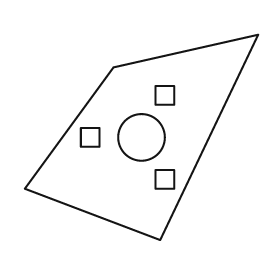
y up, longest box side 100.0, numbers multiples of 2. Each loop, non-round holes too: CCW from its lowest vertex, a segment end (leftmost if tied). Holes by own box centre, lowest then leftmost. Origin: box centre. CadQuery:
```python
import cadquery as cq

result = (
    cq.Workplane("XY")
    .moveTo(8.0, -44.0)
    .lineTo(50.0, 44.0)
    .lineTo(-12.0, 30.0)
    .lineTo(-50.0, -22.0)
    .close()
    .moveTo(6.0, -22.0)
    .lineTo(14.0, -22.0)
    .lineTo(14.0, -14.0)
    .lineTo(6.0, -14.0)
    .close()
    .moveTo(-26.0, -4.0)
    .lineTo(-18.0, -4.0)
    .lineTo(-18.0, 4.0)
    .lineTo(-26.0, 4.0)
    .close()
    .moveTo(0.0, 0.0)
    .circle(10.0)
    .moveTo(6.0, 14.0)
    .lineTo(14.0, 14.0)
    .lineTo(14.0, 22.0)
    .lineTo(6.0, 22.0)
    .close()
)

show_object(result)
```